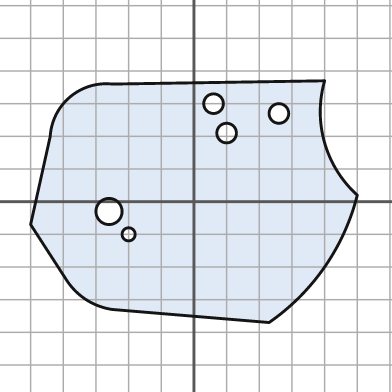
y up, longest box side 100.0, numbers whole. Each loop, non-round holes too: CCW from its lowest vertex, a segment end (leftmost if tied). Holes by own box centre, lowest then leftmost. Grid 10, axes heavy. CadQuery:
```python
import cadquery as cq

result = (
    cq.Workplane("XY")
    .moveTo(23.0, -37.0)
    .threePointArc((40.0, -20.0), (50.0, 2.0))
    .threePointArc((40.0, 18.0), (40.0, 37.0))
    .lineTo(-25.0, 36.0)
    .threePointArc((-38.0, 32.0), (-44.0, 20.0))
    .lineTo(-50.0, -7.0)
    .lineTo(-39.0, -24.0)
    .threePointArc((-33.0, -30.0), (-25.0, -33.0))
    .close()
    .moveTo(-20.0, -10.0)
    .circle(2.0)
    .moveTo(-26.0, -3.0)
    .circle(4.0)
    .moveTo(10.0, 21.0)
    .circle(3.0)
    .moveTo(26.0, 27.0)
    .circle(3.0)
    .moveTo(6.0, 30.0)
    .circle(3.0)
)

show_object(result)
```